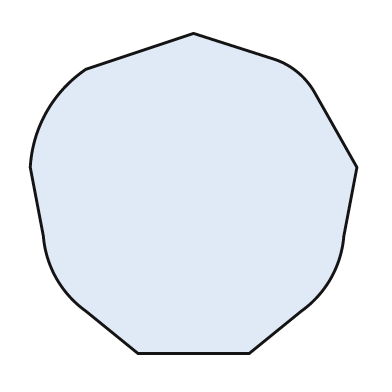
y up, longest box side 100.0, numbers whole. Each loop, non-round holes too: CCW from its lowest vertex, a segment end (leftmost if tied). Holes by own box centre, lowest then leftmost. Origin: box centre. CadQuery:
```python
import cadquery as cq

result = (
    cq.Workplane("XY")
    .moveTo(-17.0, -49.0)
    .lineTo(17.0, -49.0)
    .lineTo(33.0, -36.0)
    .threePointArc((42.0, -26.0), (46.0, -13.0))
    .lineTo(50.0, 8.0)
    .lineTo(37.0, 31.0)
    .threePointArc((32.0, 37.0), (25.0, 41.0))
    .lineTo(0.0, 49.0)
    .lineTo(-33.0, 38.0)
    .threePointArc((-45.0, 25.0), (-50.0, 8.0))
    .lineTo(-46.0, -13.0)
    .threePointArc((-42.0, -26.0), (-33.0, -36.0))
    .close()
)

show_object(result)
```